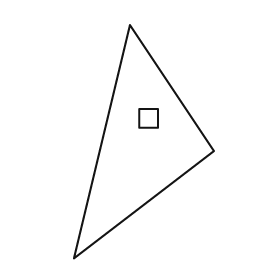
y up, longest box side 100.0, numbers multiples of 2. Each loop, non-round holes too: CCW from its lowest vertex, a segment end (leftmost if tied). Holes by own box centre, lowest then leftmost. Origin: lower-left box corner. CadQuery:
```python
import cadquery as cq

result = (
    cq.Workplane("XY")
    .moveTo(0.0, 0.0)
    .lineTo(60.0, 46.0)
    .lineTo(24.0, 100.0)
    .close()
    .moveTo(28.0, 56.0)
    .lineTo(36.0, 56.0)
    .lineTo(36.0, 64.0)
    .lineTo(28.0, 64.0)
    .close()
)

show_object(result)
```